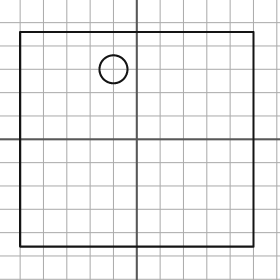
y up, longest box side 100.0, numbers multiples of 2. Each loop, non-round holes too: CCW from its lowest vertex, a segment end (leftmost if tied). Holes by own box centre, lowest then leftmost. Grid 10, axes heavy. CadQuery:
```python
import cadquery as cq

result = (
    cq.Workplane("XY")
    .moveTo(-50.0, -46.0)
    .lineTo(50.0, -46.0)
    .lineTo(50.0, 46.0)
    .lineTo(-50.0, 46.0)
    .close()
    .moveTo(-10.0, 30.0)
    .circle(6.0)
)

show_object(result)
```